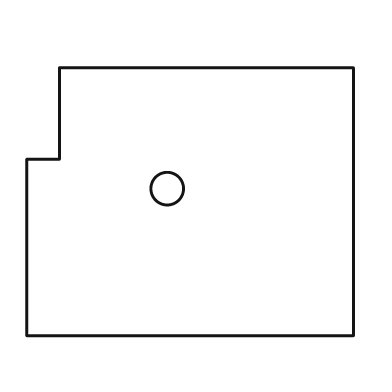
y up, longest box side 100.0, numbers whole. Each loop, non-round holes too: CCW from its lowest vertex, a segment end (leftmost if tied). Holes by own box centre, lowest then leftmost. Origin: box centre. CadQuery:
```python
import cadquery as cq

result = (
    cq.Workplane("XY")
    .moveTo(-50.0, -41.0)
    .lineTo(50.0, -41.0)
    .lineTo(50.0, 41.0)
    .lineTo(-40.0, 41.0)
    .lineTo(-40.0, 13.0)
    .lineTo(-50.0, 13.0)
    .close()
    .moveTo(-7.0, 4.0)
    .circle(5.0)
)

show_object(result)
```